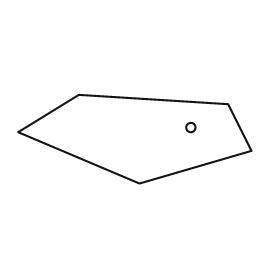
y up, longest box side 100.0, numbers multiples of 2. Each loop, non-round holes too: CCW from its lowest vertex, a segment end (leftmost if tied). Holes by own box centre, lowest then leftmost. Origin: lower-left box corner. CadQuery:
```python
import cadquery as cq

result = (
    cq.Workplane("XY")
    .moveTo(52.0, 0.0)
    .lineTo(100.0, 14.0)
    .lineTo(90.0, 34.0)
    .lineTo(26.0, 38.0)
    .lineTo(0.0, 22.0)
    .close()
    .moveTo(74.0, 24.0)
    .circle(2.0)
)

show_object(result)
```